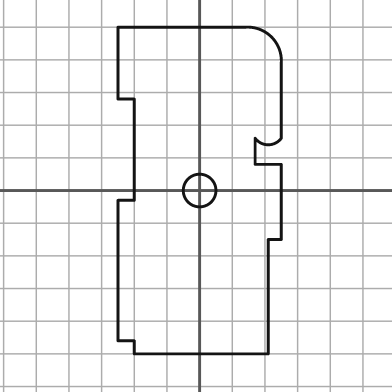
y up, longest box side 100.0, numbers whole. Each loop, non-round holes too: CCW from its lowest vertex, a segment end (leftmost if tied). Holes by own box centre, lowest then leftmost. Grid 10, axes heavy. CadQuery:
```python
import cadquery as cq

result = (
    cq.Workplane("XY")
    .moveTo(-20.0, -50.0)
    .lineTo(21.0, -50.0)
    .lineTo(21.0, -15.0)
    .lineTo(25.0, -15.0)
    .lineTo(25.0, 8.0)
    .lineTo(17.0, 8.0)
    .lineTo(17.0, 16.0)
    .threePointArc((21.0, 14.0), (25.0, 16.0))
    .lineTo(25.0, 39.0)
    .threePointArc((22.0, 47.0), (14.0, 50.0))
    .lineTo(-25.0, 50.0)
    .lineTo(-25.0, 28.0)
    .lineTo(-20.0, 28.0)
    .lineTo(-20.0, -3.0)
    .lineTo(-25.0, -3.0)
    .lineTo(-25.0, -46.0)
    .lineTo(-20.0, -46.0)
    .close()
    .moveTo(0.0, 0.0)
    .circle(5.0)
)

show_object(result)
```